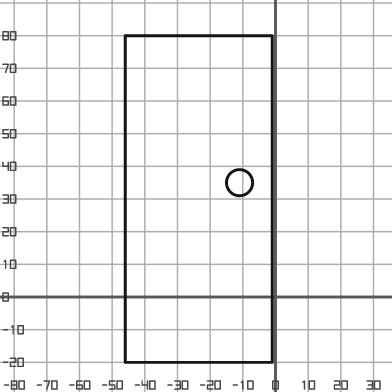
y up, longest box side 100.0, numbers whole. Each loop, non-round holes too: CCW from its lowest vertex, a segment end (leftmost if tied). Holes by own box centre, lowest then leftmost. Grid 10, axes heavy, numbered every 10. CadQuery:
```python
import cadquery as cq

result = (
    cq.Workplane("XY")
    .moveTo(-46.0, -20.0)
    .lineTo(-1.0, -20.0)
    .lineTo(-1.0, 80.0)
    .lineTo(-46.0, 80.0)
    .close()
    .moveTo(-11.0, 35.0)
    .circle(4.0)
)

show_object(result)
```